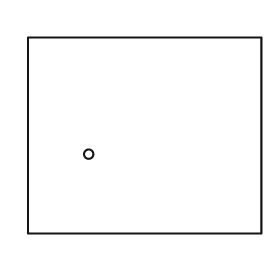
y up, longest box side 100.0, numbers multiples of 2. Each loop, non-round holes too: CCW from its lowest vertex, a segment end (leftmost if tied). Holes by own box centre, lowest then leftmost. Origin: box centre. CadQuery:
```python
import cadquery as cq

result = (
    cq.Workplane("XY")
    .moveTo(-50.0, -42.0)
    .lineTo(50.0, -42.0)
    .lineTo(50.0, 42.0)
    .lineTo(-50.0, 42.0)
    .close()
    .moveTo(-24.0, -8.0)
    .circle(2.0)
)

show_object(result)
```